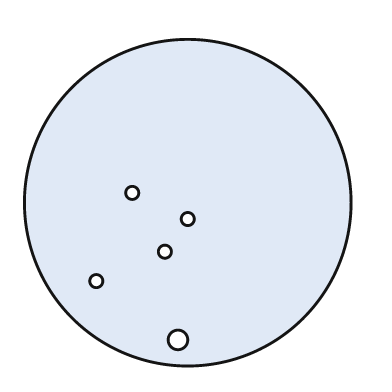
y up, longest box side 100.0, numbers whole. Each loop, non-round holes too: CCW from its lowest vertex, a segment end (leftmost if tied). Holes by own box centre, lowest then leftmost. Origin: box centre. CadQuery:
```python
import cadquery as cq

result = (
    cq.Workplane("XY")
    .moveTo(0.0, 0.0)
    .circle(50.0)
    .moveTo(-3.0, -42.0)
    .circle(3.0)
    .moveTo(-28.0, -24.0)
    .circle(2.0)
    .moveTo(-7.0, -15.0)
    .circle(2.0)
    .moveTo(0.0, -5.0)
    .circle(2.0)
    .moveTo(-17.0, 3.0)
    .circle(2.0)
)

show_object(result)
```